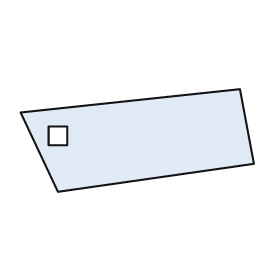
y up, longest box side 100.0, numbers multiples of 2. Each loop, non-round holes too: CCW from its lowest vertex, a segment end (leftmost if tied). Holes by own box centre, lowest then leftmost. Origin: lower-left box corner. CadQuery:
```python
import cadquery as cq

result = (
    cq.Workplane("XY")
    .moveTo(16.0, 0.0)
    .lineTo(100.0, 12.0)
    .lineTo(94.0, 44.0)
    .lineTo(0.0, 34.0)
    .close()
    .moveTo(12.0, 20.0)
    .lineTo(20.0, 20.0)
    .lineTo(20.0, 28.0)
    .lineTo(12.0, 28.0)
    .close()
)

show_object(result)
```